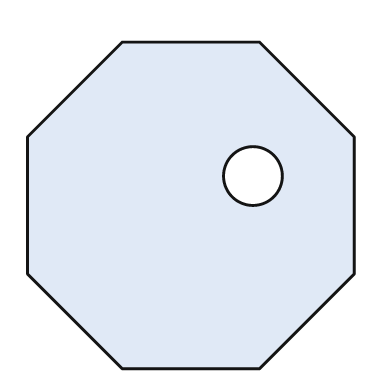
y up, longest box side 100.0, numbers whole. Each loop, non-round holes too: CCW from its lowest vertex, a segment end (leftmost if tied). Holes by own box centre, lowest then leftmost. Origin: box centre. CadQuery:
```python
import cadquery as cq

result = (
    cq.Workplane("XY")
    .moveTo(-21.0, -50.0)
    .lineTo(21.0, -50.0)
    .lineTo(50.0, -21.0)
    .lineTo(50.0, 21.0)
    .lineTo(21.0, 50.0)
    .lineTo(-21.0, 50.0)
    .lineTo(-50.0, 21.0)
    .lineTo(-50.0, -21.0)
    .close()
    .moveTo(19.0, 9.0)
    .circle(9.0)
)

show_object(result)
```